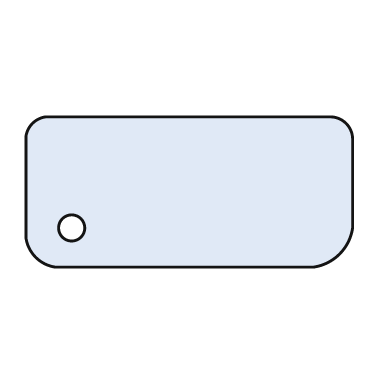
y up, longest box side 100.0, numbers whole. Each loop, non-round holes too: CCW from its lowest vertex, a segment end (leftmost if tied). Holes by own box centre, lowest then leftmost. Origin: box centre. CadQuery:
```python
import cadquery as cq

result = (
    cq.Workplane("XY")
    .moveTo(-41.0, -23.0)
    .lineTo(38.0, -23.0)
    .threePointArc((46.0, -19.0), (50.0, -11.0))
    .lineTo(50.0, 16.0)
    .threePointArc((48.0, 21.0), (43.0, 23.0))
    .lineTo(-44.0, 23.0)
    .threePointArc((-48.0, 21.0), (-50.0, 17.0))
    .lineTo(-50.0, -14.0)
    .threePointArc((-47.0, -20.0), (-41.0, -23.0))
    .close()
    .moveTo(-36.0, -11.0)
    .circle(4.0)
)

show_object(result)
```